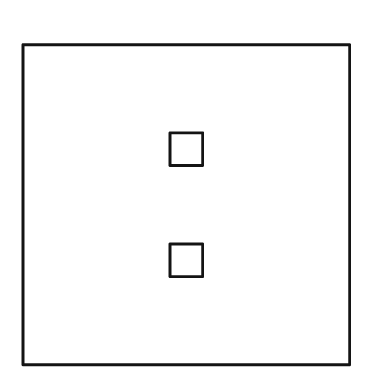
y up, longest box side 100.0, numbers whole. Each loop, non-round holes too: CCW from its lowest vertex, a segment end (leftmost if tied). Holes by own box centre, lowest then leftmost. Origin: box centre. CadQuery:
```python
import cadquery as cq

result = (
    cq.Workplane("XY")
    .moveTo(-50.0, -49.0)
    .lineTo(50.0, -49.0)
    .lineTo(50.0, 49.0)
    .lineTo(-50.0, 49.0)
    .close()
    .moveTo(-5.0, -22.0)
    .lineTo(5.0, -22.0)
    .lineTo(5.0, -12.0)
    .lineTo(-5.0, -12.0)
    .close()
    .moveTo(-5.0, 12.0)
    .lineTo(5.0, 12.0)
    .lineTo(5.0, 22.0)
    .lineTo(-5.0, 22.0)
    .close()
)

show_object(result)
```